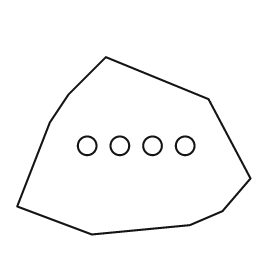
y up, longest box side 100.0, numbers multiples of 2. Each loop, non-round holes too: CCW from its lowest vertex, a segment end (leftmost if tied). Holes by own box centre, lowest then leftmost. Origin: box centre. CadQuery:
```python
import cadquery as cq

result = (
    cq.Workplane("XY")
    .moveTo(-18.0, -38.0)
    .lineTo(24.0, -34.0)
    .lineTo(38.0, -28.0)
    .lineTo(50.0, -14.0)
    .lineTo(32.0, 20.0)
    .lineTo(-12.0, 38.0)
    .lineTo(-28.0, 22.0)
    .lineTo(-36.0, 10.0)
    .lineTo(-50.0, -26.0)
    .close()
    .moveTo(-20.0, 0.0)
    .circle(4.0)
    .moveTo(-6.0, 0.0)
    .circle(4.0)
    .moveTo(8.0, 0.0)
    .circle(4.0)
    .moveTo(22.0, 0.0)
    .circle(4.0)
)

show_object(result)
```